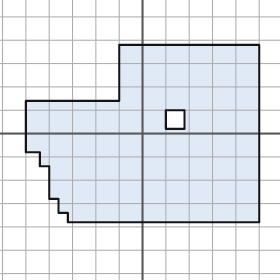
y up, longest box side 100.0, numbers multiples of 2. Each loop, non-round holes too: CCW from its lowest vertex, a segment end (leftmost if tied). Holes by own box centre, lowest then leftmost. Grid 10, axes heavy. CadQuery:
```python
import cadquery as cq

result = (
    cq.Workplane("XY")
    .moveTo(-32.0, -38.0)
    .lineTo(50.0, -38.0)
    .lineTo(50.0, 38.0)
    .lineTo(-10.0, 38.0)
    .lineTo(-10.0, 14.0)
    .lineTo(-50.0, 14.0)
    .lineTo(-50.0, -8.0)
    .lineTo(-44.0, -8.0)
    .lineTo(-44.0, -14.0)
    .lineTo(-40.0, -14.0)
    .lineTo(-40.0, -28.0)
    .lineTo(-36.0, -28.0)
    .lineTo(-36.0, -34.0)
    .lineTo(-32.0, -34.0)
    .close()
    .moveTo(10.0, 2.0)
    .lineTo(18.0, 2.0)
    .lineTo(18.0, 10.0)
    .lineTo(10.0, 10.0)
    .close()
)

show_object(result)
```